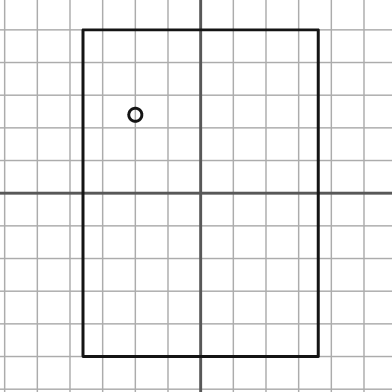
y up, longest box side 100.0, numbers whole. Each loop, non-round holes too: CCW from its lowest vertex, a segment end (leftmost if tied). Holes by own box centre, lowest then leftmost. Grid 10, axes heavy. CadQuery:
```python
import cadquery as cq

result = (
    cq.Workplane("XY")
    .moveTo(-36.0, -50.0)
    .lineTo(36.0, -50.0)
    .lineTo(36.0, 50.0)
    .lineTo(-36.0, 50.0)
    .close()
    .moveTo(-20.0, 24.0)
    .circle(2.0)
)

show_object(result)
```